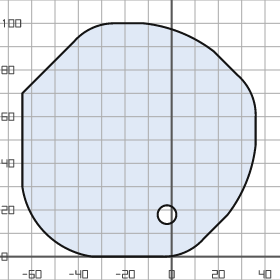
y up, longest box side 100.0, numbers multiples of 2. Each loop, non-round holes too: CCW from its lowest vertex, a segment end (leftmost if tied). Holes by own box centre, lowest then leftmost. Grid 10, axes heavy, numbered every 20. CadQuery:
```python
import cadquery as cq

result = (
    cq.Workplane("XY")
    .moveTo(-34.0, 0.0)
    .lineTo(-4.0, 0.0)
    .threePointArc((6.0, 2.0), (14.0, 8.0))
    .lineTo(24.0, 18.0)
    .threePointArc((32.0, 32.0), (36.0, 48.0))
    .lineTo(36.0, 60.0)
    .threePointArc((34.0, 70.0), (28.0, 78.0))
    .lineTo(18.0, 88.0)
    .threePointArc((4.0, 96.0), (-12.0, 100.0))
    .lineTo(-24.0, 100.0)
    .threePointArc((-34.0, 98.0), (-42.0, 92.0))
    .lineTo(-64.0, 70.0)
    .lineTo(-64.0, 30.0)
    .threePointArc((-54.0, 10.0), (-34.0, 0.0))
    .close()
    .moveTo(-2.0, 18.0)
    .circle(4.0)
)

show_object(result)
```